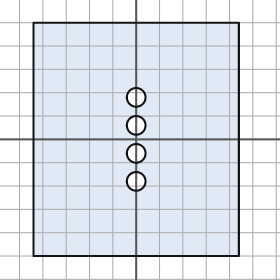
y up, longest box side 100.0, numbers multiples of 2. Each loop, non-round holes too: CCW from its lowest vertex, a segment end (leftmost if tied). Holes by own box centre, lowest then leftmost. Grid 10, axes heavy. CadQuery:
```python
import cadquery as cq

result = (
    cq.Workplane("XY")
    .moveTo(-44.0, -50.0)
    .lineTo(44.0, -50.0)
    .lineTo(44.0, 50.0)
    .lineTo(-44.0, 50.0)
    .close()
    .moveTo(0.0, -18.0)
    .circle(4.0)
    .moveTo(0.0, -6.0)
    .circle(4.0)
    .moveTo(0.0, 6.0)
    .circle(4.0)
    .moveTo(0.0, 18.0)
    .circle(4.0)
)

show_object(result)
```